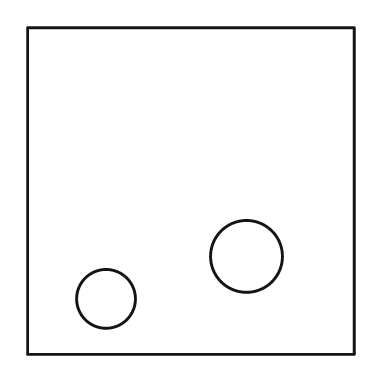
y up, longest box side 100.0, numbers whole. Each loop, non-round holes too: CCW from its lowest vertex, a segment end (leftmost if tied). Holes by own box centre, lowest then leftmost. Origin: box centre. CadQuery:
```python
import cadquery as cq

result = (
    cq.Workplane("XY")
    .moveTo(-50.0, -50.0)
    .lineTo(50.0, -50.0)
    .lineTo(50.0, 50.0)
    .lineTo(-50.0, 50.0)
    .close()
    .moveTo(-26.0, -33.0)
    .circle(9.0)
    .moveTo(17.0, -20.0)
    .circle(11.0)
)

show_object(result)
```